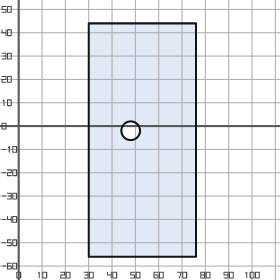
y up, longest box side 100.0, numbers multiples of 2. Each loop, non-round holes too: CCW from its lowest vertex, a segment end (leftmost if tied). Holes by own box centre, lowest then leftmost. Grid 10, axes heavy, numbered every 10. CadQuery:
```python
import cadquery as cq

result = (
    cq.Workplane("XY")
    .moveTo(30.0, -56.0)
    .lineTo(76.0, -56.0)
    .lineTo(76.0, 44.0)
    .lineTo(30.0, 44.0)
    .close()
    .moveTo(48.0, -2.0)
    .circle(4.0)
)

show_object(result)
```